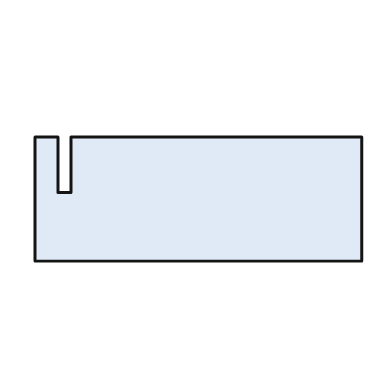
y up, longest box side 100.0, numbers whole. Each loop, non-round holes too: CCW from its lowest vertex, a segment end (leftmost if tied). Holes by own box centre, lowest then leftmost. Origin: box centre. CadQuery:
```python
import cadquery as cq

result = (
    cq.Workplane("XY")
    .moveTo(-50.0, -19.0)
    .lineTo(50.0, -19.0)
    .lineTo(50.0, 19.0)
    .lineTo(-39.0, 19.0)
    .lineTo(-39.0, 2.0)
    .lineTo(-43.0, 2.0)
    .lineTo(-43.0, 19.0)
    .lineTo(-50.0, 19.0)
    .close()
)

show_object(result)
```